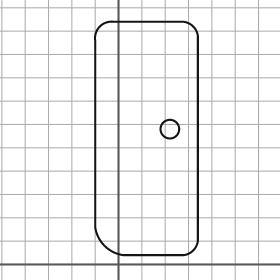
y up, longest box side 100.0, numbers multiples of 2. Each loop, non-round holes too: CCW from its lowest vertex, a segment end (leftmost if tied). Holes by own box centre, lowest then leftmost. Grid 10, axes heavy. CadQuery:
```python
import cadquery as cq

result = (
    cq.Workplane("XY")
    .moveTo(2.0, 4.0)
    .lineTo(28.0, 4.0)
    .threePointArc((32.0, 6.0), (34.0, 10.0))
    .lineTo(34.0, 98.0)
    .threePointArc((32.0, 102.0), (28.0, 104.0))
    .lineTo(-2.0, 104.0)
    .threePointArc((-8.0, 102.0), (-10.0, 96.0))
    .lineTo(-10.0, 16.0)
    .threePointArc((-6.0, 8.0), (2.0, 4.0))
    .close()
    .moveTo(22.0, 58.0)
    .circle(4.0)
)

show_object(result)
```